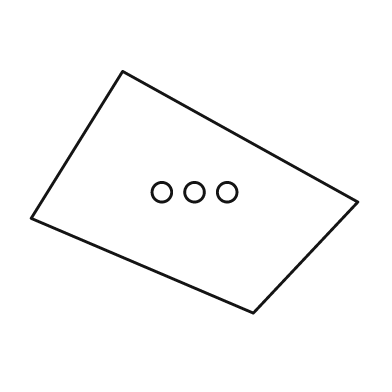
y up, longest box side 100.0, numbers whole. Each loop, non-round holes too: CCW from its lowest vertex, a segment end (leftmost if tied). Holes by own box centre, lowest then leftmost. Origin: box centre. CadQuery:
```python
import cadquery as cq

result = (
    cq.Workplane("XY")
    .moveTo(18.0, -37.0)
    .lineTo(50.0, -3.0)
    .lineTo(-22.0, 37.0)
    .lineTo(-50.0, -8.0)
    .close()
    .moveTo(-10.0, 0.0)
    .circle(3.0)
    .moveTo(0.0, 0.0)
    .circle(3.0)
    .moveTo(10.0, 0.0)
    .circle(3.0)
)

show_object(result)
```